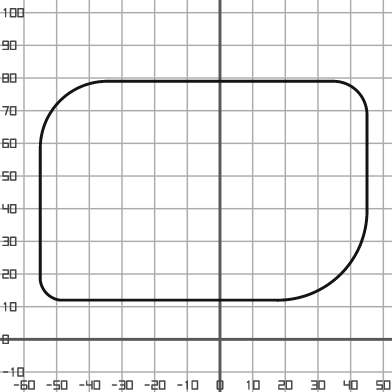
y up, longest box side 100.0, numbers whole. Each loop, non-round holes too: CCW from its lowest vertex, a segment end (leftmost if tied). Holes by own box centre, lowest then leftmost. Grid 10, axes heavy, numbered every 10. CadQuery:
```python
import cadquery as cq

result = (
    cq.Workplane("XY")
    .moveTo(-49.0, 12.0)
    .lineTo(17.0, 12.0)
    .threePointArc((37.0, 20.0), (45.0, 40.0))
    .lineTo(45.0, 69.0)
    .threePointArc((42.0, 76.0), (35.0, 79.0))
    .lineTo(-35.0, 79.0)
    .threePointArc((-49.0, 73.0), (-55.0, 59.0))
    .lineTo(-55.0, 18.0)
    .threePointArc((-53.0, 14.0), (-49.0, 12.0))
    .close()
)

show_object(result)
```